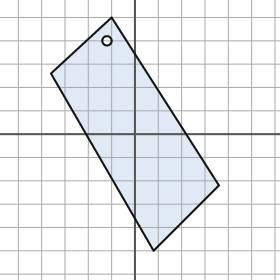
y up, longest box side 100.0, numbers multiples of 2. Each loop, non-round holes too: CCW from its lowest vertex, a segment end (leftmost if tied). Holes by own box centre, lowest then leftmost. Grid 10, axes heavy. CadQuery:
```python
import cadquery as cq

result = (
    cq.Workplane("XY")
    .moveTo(8.0, -50.0)
    .lineTo(36.0, -22.0)
    .lineTo(-10.0, 50.0)
    .lineTo(-36.0, 26.0)
    .close()
    .moveTo(-12.0, 40.0)
    .circle(2.0)
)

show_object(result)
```